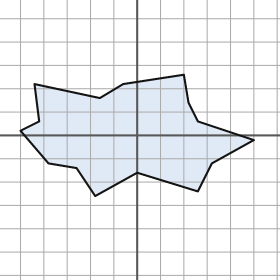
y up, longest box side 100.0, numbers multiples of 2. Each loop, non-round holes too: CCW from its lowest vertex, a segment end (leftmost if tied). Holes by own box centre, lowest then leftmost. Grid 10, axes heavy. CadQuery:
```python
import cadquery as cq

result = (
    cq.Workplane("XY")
    .moveTo(-18.0, -26.0)
    .lineTo(0.0, -16.0)
    .lineTo(26.0, -24.0)
    .lineTo(32.0, -12.0)
    .lineTo(50.0, -2.0)
    .lineTo(26.0, 6.0)
    .lineTo(22.0, 14.0)
    .lineTo(20.0, 26.0)
    .lineTo(-6.0, 22.0)
    .lineTo(-16.0, 16.0)
    .lineTo(-44.0, 22.0)
    .lineTo(-42.0, 6.0)
    .lineTo(-50.0, 2.0)
    .lineTo(-38.0, -12.0)
    .lineTo(-26.0, -14.0)
    .close()
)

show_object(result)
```